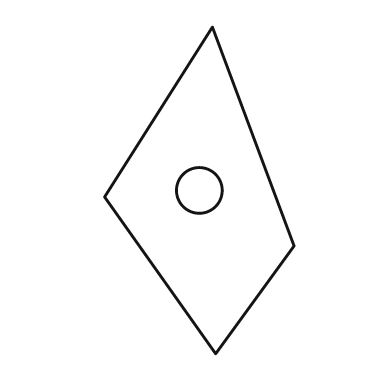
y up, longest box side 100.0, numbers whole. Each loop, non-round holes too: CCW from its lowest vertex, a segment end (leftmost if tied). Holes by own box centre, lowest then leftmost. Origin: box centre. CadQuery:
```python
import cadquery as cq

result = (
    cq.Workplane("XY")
    .moveTo(5.0, -50.0)
    .lineTo(29.0, -17.0)
    .lineTo(4.0, 50.0)
    .lineTo(-29.0, -2.0)
    .close()
    .moveTo(0.0, 0.0)
    .circle(7.0)
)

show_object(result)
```